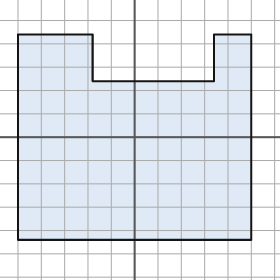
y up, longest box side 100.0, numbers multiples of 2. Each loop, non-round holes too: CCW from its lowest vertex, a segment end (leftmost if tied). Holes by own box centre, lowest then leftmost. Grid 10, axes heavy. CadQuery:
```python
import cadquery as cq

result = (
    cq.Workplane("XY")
    .moveTo(-50.0, -44.0)
    .lineTo(50.0, -44.0)
    .lineTo(50.0, 44.0)
    .lineTo(34.0, 44.0)
    .lineTo(34.0, 24.0)
    .lineTo(-18.0, 24.0)
    .lineTo(-18.0, 44.0)
    .lineTo(-50.0, 44.0)
    .close()
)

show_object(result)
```